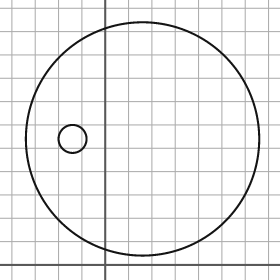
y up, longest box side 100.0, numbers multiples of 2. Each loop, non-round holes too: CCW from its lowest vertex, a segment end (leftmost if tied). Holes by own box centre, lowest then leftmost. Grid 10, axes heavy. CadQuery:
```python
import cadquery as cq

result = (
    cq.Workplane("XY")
    .moveTo(16.0, 54.0)
    .circle(50.0)
    .moveTo(-14.0, 54.0)
    .circle(6.0)
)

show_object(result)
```